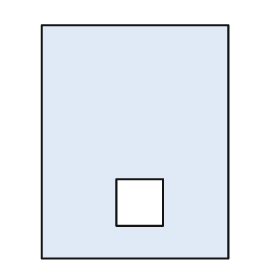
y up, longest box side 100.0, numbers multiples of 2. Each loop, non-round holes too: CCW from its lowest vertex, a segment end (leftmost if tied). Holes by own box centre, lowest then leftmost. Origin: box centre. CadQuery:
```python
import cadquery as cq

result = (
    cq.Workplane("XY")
    .moveTo(-40.0, -50.0)
    .lineTo(40.0, -50.0)
    .lineTo(40.0, 50.0)
    .lineTo(-40.0, 50.0)
    .close()
    .moveTo(-8.0, -36.0)
    .lineTo(12.0, -36.0)
    .lineTo(12.0, -16.0)
    .lineTo(-8.0, -16.0)
    .close()
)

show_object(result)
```